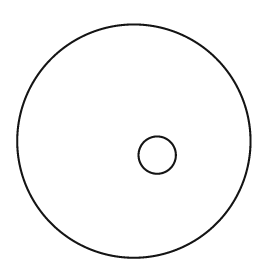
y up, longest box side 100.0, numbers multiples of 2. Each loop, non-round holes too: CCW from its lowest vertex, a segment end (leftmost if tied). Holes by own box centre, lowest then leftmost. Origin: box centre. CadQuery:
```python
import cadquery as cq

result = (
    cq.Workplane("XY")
    .moveTo(0.0, 0.0)
    .circle(50.0)
    .moveTo(10.0, -6.0)
    .circle(8.0)
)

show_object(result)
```